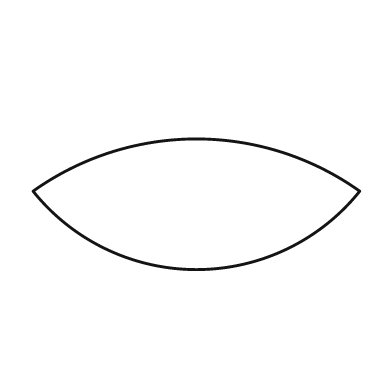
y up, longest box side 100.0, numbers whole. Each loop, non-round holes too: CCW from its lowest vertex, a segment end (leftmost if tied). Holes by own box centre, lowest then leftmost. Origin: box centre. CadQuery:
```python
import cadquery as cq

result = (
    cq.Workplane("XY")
    .moveTo(-50.0, 4.0)
    .threePointArc((0.0, -20.0), (50.0, 4.0))
    .threePointArc((0.0, 20.0), (-50.0, 4.0))
    .close()
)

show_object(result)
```